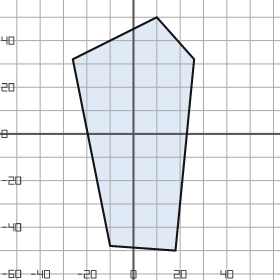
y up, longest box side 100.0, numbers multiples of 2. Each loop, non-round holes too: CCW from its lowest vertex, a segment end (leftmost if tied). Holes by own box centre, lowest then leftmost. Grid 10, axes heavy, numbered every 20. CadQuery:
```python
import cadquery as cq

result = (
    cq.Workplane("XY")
    .moveTo(18.0, -50.0)
    .lineTo(26.0, 32.0)
    .lineTo(10.0, 50.0)
    .lineTo(-26.0, 32.0)
    .lineTo(-10.0, -48.0)
    .close()
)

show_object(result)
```